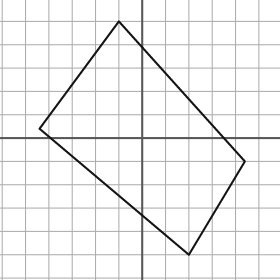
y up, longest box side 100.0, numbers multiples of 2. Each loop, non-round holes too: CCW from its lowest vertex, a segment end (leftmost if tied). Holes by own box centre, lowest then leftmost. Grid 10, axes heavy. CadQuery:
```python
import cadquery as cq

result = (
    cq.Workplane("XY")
    .moveTo(20.0, -50.0)
    .lineTo(44.0, -10.0)
    .lineTo(-10.0, 50.0)
    .lineTo(-44.0, 4.0)
    .close()
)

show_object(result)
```